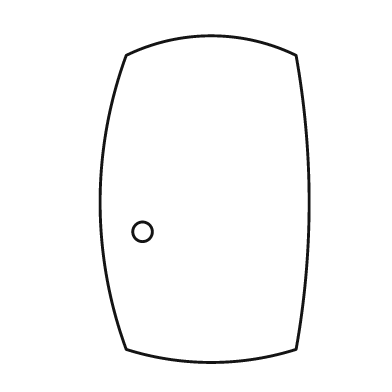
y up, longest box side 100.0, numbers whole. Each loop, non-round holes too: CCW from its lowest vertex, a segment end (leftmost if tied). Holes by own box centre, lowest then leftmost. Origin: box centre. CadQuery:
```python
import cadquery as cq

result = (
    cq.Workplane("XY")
    .moveTo(-24.0, -46.0)
    .threePointArc((2.0, -50.0), (28.0, -46.0))
    .threePointArc((32.0, -1.0), (28.0, 44.0))
    .threePointArc((2.0, 50.0), (-24.0, 44.0))
    .threePointArc((-32.0, -1.0), (-24.0, -46.0))
    .close()
    .moveTo(-19.0, -10.0)
    .circle(3.0)
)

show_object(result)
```